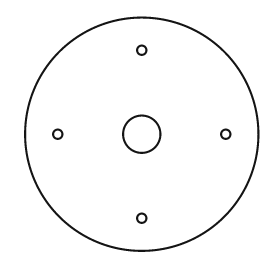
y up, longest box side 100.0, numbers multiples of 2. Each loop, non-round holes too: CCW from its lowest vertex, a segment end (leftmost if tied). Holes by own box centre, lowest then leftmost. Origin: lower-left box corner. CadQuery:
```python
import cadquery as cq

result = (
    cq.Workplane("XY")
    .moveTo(50.0, 50.0)
    .circle(50.0)
    .moveTo(50.0, 14.0)
    .circle(2.0)
    .moveTo(14.0, 50.0)
    .circle(2.0)
    .moveTo(50.0, 50.0)
    .circle(8.0)
    .moveTo(86.0, 50.0)
    .circle(2.0)
    .moveTo(50.0, 86.0)
    .circle(2.0)
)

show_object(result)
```